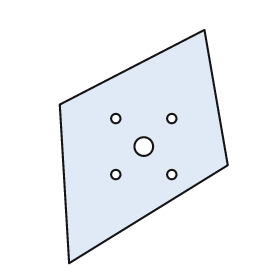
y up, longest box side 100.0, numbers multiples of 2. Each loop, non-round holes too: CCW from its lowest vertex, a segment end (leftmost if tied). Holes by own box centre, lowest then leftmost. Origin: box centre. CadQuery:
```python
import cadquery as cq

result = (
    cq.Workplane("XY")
    .moveTo(-32.0, -50.0)
    .lineTo(36.0, -8.0)
    .lineTo(26.0, 50.0)
    .lineTo(-36.0, 18.0)
    .close()
    .moveTo(-12.0, -12.0)
    .circle(2.0)
    .moveTo(12.0, -12.0)
    .circle(2.0)
    .moveTo(0.0, 0.0)
    .circle(4.0)
    .moveTo(-12.0, 12.0)
    .circle(2.0)
    .moveTo(12.0, 12.0)
    .circle(2.0)
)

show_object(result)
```